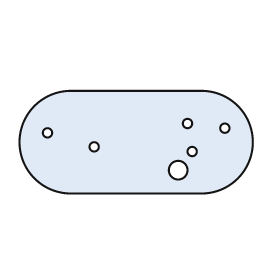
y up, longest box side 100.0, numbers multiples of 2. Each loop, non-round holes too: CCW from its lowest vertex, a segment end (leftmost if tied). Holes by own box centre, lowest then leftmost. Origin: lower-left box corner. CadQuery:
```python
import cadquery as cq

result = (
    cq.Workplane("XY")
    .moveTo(22.0, 0.0)
    .lineTo(78.0, 0.0)
    .threePointArc((100.0, 22.0), (78.0, 44.0))
    .lineTo(22.0, 44.0)
    .threePointArc((0.0, 22.0), (22.0, 0.0))
    .close()
    .moveTo(68.0, 10.0)
    .circle(4.0)
    .moveTo(74.0, 18.0)
    .circle(2.0)
    .moveTo(32.0, 20.0)
    .circle(2.0)
    .moveTo(12.0, 26.0)
    .circle(2.0)
    .moveTo(88.0, 28.0)
    .circle(2.0)
    .moveTo(72.0, 30.0)
    .circle(2.0)
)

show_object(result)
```